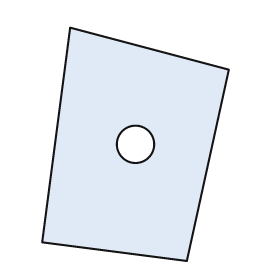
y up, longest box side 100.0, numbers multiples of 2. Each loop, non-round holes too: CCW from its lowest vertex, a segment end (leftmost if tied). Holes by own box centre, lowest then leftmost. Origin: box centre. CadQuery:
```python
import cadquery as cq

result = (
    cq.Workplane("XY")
    .moveTo(22.0, -50.0)
    .lineTo(40.0, 32.0)
    .lineTo(-28.0, 50.0)
    .lineTo(-40.0, -42.0)
    .close()
    .moveTo(0.0, 0.0)
    .circle(8.0)
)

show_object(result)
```